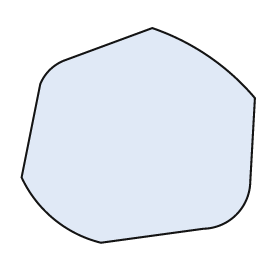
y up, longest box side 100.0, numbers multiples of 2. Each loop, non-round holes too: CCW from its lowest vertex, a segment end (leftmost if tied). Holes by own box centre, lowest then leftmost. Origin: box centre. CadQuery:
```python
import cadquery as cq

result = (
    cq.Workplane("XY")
    .moveTo(-16.0, -46.0)
    .lineTo(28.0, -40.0)
    .threePointArc((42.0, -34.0), (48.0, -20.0))
    .lineTo(50.0, 16.0)
    .threePointArc((30.0, 34.0), (6.0, 46.0))
    .lineTo(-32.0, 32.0)
    .threePointArc((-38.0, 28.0), (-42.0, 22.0))
    .lineTo(-50.0, -18.0)
    .threePointArc((-36.0, -36.0), (-16.0, -46.0))
    .close()
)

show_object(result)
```